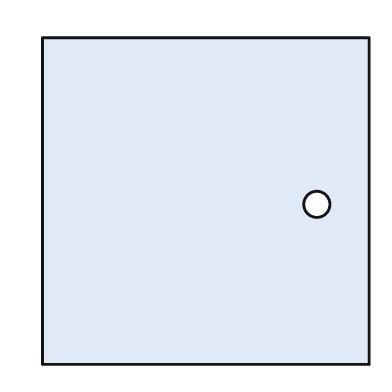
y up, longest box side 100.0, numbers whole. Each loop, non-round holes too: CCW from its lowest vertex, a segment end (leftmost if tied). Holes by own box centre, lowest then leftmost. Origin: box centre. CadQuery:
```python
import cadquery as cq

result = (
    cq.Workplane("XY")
    .moveTo(-50.0, -50.0)
    .lineTo(50.0, -50.0)
    .lineTo(50.0, 50.0)
    .lineTo(-50.0, 50.0)
    .close()
    .moveTo(34.0, -1.0)
    .circle(4.0)
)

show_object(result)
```